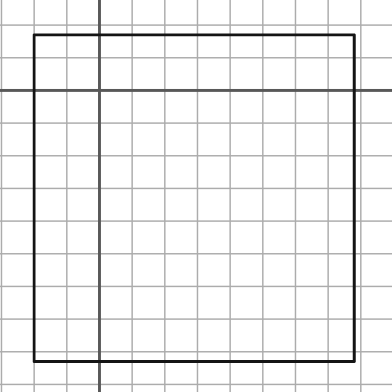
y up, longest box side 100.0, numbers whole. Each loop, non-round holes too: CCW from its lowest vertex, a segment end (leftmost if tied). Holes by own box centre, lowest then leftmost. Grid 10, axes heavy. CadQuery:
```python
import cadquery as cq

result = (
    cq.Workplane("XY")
    .moveTo(-20.0, -83.0)
    .lineTo(78.0, -83.0)
    .lineTo(78.0, 17.0)
    .lineTo(-20.0, 17.0)
    .close()
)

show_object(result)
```